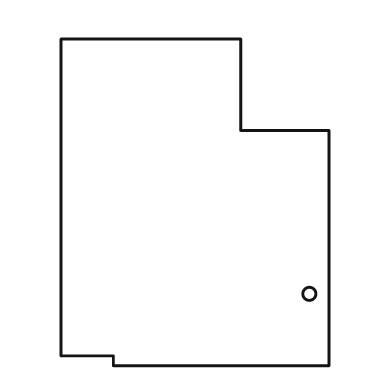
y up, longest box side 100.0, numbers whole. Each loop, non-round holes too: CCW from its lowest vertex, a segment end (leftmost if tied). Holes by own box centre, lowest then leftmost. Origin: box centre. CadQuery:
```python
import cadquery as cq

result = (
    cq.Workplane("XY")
    .moveTo(-25.0, -50.0)
    .lineTo(41.0, -50.0)
    .lineTo(41.0, 22.0)
    .lineTo(14.0, 22.0)
    .lineTo(14.0, 50.0)
    .lineTo(-41.0, 50.0)
    .lineTo(-41.0, -47.0)
    .lineTo(-25.0, -47.0)
    .close()
    .moveTo(35.0, -28.0)
    .circle(2.0)
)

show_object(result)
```